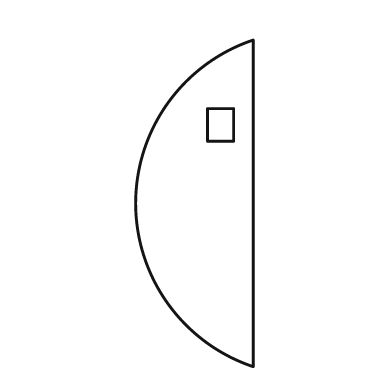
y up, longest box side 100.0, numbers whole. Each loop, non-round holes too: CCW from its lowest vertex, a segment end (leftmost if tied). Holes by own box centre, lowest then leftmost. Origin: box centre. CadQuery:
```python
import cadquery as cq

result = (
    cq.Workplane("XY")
    .moveTo(18.0, -50.0)
    .lineTo(18.0, 50.0)
    .threePointArc((-18.0, 0.0), (18.0, -50.0))
    .close()
    .moveTo(4.0, 19.0)
    .lineTo(12.0, 19.0)
    .lineTo(12.0, 29.0)
    .lineTo(4.0, 29.0)
    .close()
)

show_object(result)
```